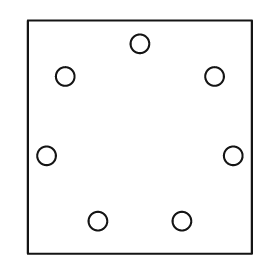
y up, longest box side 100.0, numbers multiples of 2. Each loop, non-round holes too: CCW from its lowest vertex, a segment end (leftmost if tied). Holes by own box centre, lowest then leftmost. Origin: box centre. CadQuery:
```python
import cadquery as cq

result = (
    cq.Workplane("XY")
    .moveTo(-48.0, -50.0)
    .lineTo(48.0, -50.0)
    .lineTo(48.0, 50.0)
    .lineTo(-48.0, 50.0)
    .close()
    .moveTo(-18.0, -36.0)
    .circle(4.0)
    .moveTo(18.0, -36.0)
    .circle(4.0)
    .moveTo(-40.0, -8.0)
    .circle(4.0)
    .moveTo(40.0, -8.0)
    .circle(4.0)
    .moveTo(-32.0, 26.0)
    .circle(4.0)
    .moveTo(32.0, 26.0)
    .circle(4.0)
    .moveTo(0.0, 40.0)
    .circle(4.0)
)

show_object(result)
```